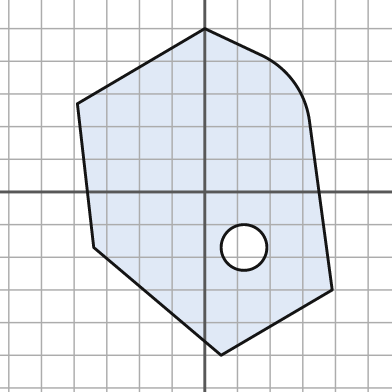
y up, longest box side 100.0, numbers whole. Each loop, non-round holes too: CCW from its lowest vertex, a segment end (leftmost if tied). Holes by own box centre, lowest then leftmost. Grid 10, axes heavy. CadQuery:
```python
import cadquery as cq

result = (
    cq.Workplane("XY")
    .moveTo(5.0, -50.0)
    .lineTo(39.0, -30.0)
    .lineTo(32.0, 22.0)
    .threePointArc((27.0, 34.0), (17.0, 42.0))
    .lineTo(0.0, 50.0)
    .lineTo(-39.0, 27.0)
    .lineTo(-34.0, -17.0)
    .close()
    .moveTo(12.0, -17.0)
    .circle(7.0)
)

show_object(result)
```